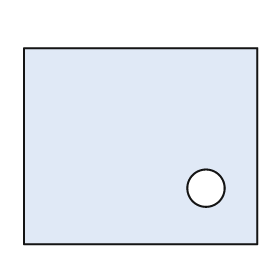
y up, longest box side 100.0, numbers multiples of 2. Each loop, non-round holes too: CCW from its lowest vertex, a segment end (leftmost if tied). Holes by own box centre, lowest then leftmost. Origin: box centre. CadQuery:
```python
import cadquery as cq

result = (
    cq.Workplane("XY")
    .moveTo(-50.0, -42.0)
    .lineTo(50.0, -42.0)
    .lineTo(50.0, 42.0)
    .lineTo(-50.0, 42.0)
    .close()
    .moveTo(28.0, -18.0)
    .circle(8.0)
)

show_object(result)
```